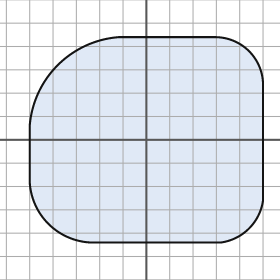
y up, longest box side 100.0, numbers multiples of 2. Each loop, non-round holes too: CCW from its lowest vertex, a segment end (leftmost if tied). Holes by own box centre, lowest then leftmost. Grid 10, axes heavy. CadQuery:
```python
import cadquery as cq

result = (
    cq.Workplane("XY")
    .moveTo(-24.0, -44.0)
    .lineTo(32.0, -44.0)
    .threePointArc((44.0, -38.0), (50.0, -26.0))
    .lineTo(50.0, 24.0)
    .threePointArc((44.0, 38.0), (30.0, 44.0))
    .lineTo(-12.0, 44.0)
    .threePointArc((-38.0, 32.0), (-50.0, 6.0))
    .lineTo(-50.0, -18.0)
    .threePointArc((-42.0, -36.0), (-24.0, -44.0))
    .close()
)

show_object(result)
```